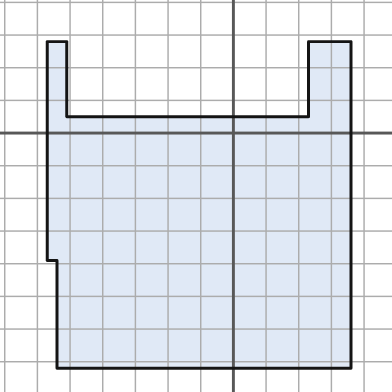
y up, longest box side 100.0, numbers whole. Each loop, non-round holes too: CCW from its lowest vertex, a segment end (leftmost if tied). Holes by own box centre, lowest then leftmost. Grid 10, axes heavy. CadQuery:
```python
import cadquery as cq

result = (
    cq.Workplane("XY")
    .moveTo(-54.0, -72.0)
    .lineTo(36.0, -72.0)
    .lineTo(36.0, 28.0)
    .lineTo(23.0, 28.0)
    .lineTo(23.0, 5.0)
    .lineTo(-51.0, 5.0)
    .lineTo(-51.0, 28.0)
    .lineTo(-57.0, 28.0)
    .lineTo(-57.0, -39.0)
    .lineTo(-54.0, -39.0)
    .close()
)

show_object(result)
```